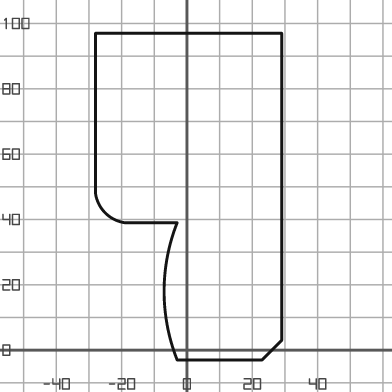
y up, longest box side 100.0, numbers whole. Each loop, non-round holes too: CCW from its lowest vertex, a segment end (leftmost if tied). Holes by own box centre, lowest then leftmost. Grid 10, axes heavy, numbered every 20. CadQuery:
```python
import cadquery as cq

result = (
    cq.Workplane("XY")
    .moveTo(-3.0, -3.0)
    .lineTo(23.0, -3.0)
    .lineTo(29.0, 3.0)
    .lineTo(29.0, 97.0)
    .lineTo(-28.0, 97.0)
    .lineTo(-28.0, 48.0)
    .threePointArc((-25.0, 42.0), (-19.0, 39.0))
    .lineTo(-3.0, 39.0)
    .threePointArc((-7.0, 18.0), (-3.0, -3.0))
    .close()
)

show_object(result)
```